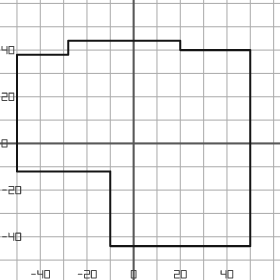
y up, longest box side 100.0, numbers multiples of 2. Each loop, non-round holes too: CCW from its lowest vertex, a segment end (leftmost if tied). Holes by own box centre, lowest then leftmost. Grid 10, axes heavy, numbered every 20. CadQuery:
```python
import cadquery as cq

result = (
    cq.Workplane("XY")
    .moveTo(-10.0, -44.0)
    .lineTo(50.0, -44.0)
    .lineTo(50.0, 40.0)
    .lineTo(20.0, 40.0)
    .lineTo(20.0, 44.0)
    .lineTo(-28.0, 44.0)
    .lineTo(-28.0, 38.0)
    .lineTo(-50.0, 38.0)
    .lineTo(-50.0, -12.0)
    .lineTo(-10.0, -12.0)
    .close()
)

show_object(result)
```